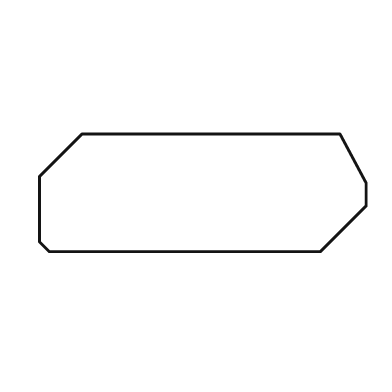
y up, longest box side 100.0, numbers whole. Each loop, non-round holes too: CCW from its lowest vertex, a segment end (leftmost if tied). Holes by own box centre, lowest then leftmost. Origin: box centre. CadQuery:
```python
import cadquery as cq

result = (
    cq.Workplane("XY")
    .moveTo(-47.0, -18.0)
    .lineTo(36.0, -18.0)
    .lineTo(50.0, -4.0)
    .lineTo(50.0, 3.0)
    .lineTo(42.0, 18.0)
    .lineTo(-37.0, 18.0)
    .lineTo(-50.0, 5.0)
    .lineTo(-50.0, -15.0)
    .close()
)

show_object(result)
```